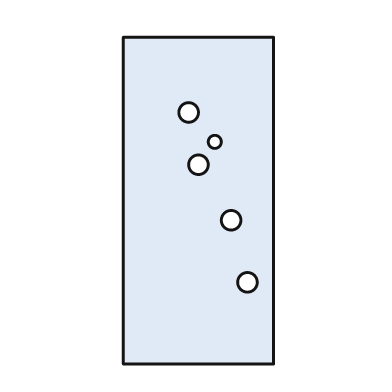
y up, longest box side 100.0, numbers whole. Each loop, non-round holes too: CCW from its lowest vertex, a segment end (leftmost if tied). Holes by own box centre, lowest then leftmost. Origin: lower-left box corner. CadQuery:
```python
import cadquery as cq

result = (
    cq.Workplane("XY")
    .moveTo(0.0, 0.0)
    .lineTo(46.0, 0.0)
    .lineTo(46.0, 100.0)
    .lineTo(0.0, 100.0)
    .close()
    .moveTo(38.0, 25.0)
    .circle(3.0)
    .moveTo(33.0, 44.0)
    .circle(3.0)
    .moveTo(23.0, 61.0)
    .circle(3.0)
    .moveTo(28.0, 68.0)
    .circle(2.0)
    .moveTo(20.0, 77.0)
    .circle(3.0)
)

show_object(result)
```